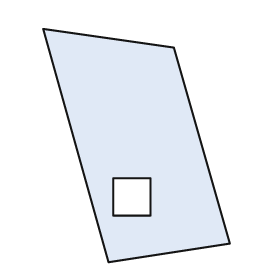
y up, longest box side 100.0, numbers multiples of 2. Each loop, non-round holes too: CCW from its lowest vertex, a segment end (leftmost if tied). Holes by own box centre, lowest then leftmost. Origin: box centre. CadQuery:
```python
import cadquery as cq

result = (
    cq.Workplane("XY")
    .moveTo(-12.0, -50.0)
    .lineTo(40.0, -42.0)
    .lineTo(16.0, 42.0)
    .lineTo(-40.0, 50.0)
    .close()
    .moveTo(-10.0, -30.0)
    .lineTo(6.0, -30.0)
    .lineTo(6.0, -14.0)
    .lineTo(-10.0, -14.0)
    .close()
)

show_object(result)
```